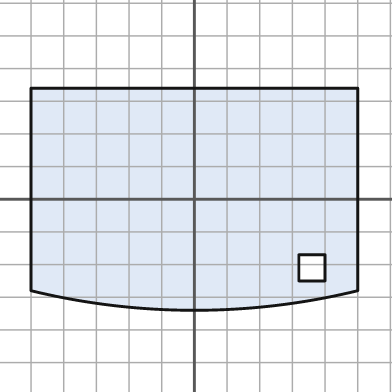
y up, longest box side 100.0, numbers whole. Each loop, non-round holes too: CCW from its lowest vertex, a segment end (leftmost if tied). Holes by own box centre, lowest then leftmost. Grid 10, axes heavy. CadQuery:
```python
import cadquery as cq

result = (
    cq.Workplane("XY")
    .moveTo(-50.0, -28.0)
    .threePointArc((0.0, -34.0), (50.0, -28.0))
    .lineTo(50.0, 34.0)
    .lineTo(-50.0, 34.0)
    .close()
    .moveTo(32.0, -25.0)
    .lineTo(40.0, -25.0)
    .lineTo(40.0, -17.0)
    .lineTo(32.0, -17.0)
    .close()
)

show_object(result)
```